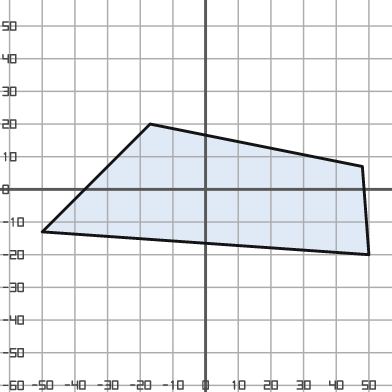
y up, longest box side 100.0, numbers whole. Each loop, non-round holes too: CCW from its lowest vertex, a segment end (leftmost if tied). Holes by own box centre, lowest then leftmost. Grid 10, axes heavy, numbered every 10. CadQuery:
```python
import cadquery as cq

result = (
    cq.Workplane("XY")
    .moveTo(50.0, -20.0)
    .lineTo(48.0, 7.0)
    .lineTo(-17.0, 20.0)
    .lineTo(-50.0, -13.0)
    .close()
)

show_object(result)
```